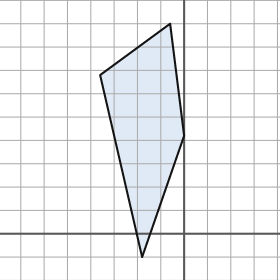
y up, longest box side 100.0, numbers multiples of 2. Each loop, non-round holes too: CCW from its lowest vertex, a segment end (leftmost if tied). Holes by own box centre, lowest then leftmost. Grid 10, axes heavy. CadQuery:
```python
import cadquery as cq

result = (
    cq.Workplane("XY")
    .moveTo(-18.0, -10.0)
    .lineTo(0.0, 42.0)
    .lineTo(-6.0, 90.0)
    .lineTo(-36.0, 68.0)
    .close()
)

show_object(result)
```